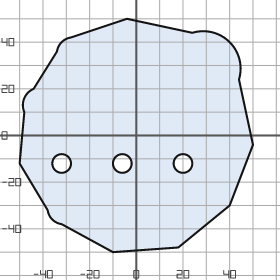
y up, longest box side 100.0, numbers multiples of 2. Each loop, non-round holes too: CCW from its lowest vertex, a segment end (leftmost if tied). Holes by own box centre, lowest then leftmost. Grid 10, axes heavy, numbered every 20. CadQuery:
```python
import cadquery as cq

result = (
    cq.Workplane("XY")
    .moveTo(-10.0, -50.0)
    .lineTo(18.0, -48.0)
    .lineTo(40.0, -30.0)
    .lineTo(50.0, -4.0)
    .lineTo(44.0, 24.0)
    .threePointArc((40.0, 40.0), (24.0, 44.0))
    .lineTo(-4.0, 50.0)
    .lineTo(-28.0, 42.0)
    .threePointArc((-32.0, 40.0), (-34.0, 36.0))
    .lineTo(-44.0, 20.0)
    .threePointArc((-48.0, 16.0), (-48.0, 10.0))
    .lineTo(-50.0, -12.0)
    .lineTo(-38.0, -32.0)
    .threePointArc((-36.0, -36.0), (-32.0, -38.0))
    .close()
    .moveTo(-32.0, -12.0)
    .circle(4.0)
    .moveTo(-6.0, -12.0)
    .circle(4.0)
    .moveTo(20.0, -12.0)
    .circle(4.0)
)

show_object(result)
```